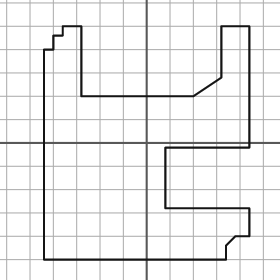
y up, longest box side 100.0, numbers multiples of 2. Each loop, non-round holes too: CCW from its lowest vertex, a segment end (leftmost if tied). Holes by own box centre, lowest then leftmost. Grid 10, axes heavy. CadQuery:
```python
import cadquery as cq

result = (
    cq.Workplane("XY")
    .moveTo(-44.0, -50.0)
    .lineTo(34.0, -50.0)
    .lineTo(34.0, -44.0)
    .lineTo(38.0, -40.0)
    .lineTo(44.0, -40.0)
    .lineTo(44.0, -28.0)
    .lineTo(8.0, -28.0)
    .lineTo(8.0, -2.0)
    .lineTo(44.0, -2.0)
    .lineTo(44.0, 50.0)
    .lineTo(32.0, 50.0)
    .lineTo(32.0, 28.0)
    .lineTo(20.0, 20.0)
    .lineTo(-28.0, 20.0)
    .lineTo(-28.0, 50.0)
    .lineTo(-36.0, 50.0)
    .lineTo(-36.0, 46.0)
    .lineTo(-40.0, 46.0)
    .lineTo(-40.0, 40.0)
    .lineTo(-44.0, 40.0)
    .close()
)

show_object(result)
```